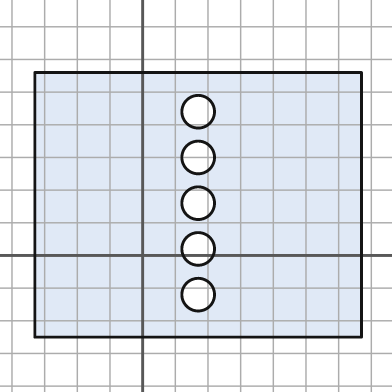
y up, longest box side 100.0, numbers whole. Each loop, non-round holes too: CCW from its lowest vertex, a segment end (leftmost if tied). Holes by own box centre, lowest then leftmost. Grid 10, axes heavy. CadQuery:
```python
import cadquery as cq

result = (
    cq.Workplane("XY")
    .moveTo(-33.0, -25.0)
    .lineTo(67.0, -25.0)
    .lineTo(67.0, 56.0)
    .lineTo(-33.0, 56.0)
    .close()
    .moveTo(17.0, -12.0)
    .circle(5.0)
    .moveTo(17.0, 2.0)
    .circle(5.0)
    .moveTo(17.0, 16.0)
    .circle(5.0)
    .moveTo(17.0, 30.0)
    .circle(5.0)
    .moveTo(17.0, 44.0)
    .circle(5.0)
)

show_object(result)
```